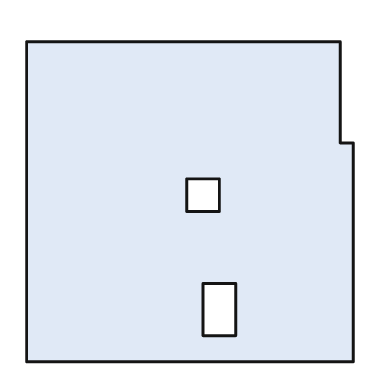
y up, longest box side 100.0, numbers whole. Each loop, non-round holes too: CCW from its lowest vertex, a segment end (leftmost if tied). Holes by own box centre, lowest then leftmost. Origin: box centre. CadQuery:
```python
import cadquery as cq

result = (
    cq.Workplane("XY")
    .moveTo(-50.0, -49.0)
    .lineTo(50.0, -49.0)
    .lineTo(50.0, 18.0)
    .lineTo(46.0, 18.0)
    .lineTo(46.0, 49.0)
    .lineTo(-50.0, 49.0)
    .close()
    .moveTo(4.0, -41.0)
    .lineTo(14.0, -41.0)
    .lineTo(14.0, -25.0)
    .lineTo(4.0, -25.0)
    .close()
    .moveTo(-1.0, -3.0)
    .lineTo(9.0, -3.0)
    .lineTo(9.0, 7.0)
    .lineTo(-1.0, 7.0)
    .close()
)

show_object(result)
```